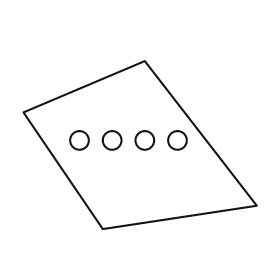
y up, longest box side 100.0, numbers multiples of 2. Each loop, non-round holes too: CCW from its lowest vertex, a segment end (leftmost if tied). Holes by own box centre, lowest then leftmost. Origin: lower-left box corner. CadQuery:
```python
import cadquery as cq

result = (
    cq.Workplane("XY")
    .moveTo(34.0, 0.0)
    .lineTo(100.0, 10.0)
    .lineTo(52.0, 72.0)
    .lineTo(0.0, 50.0)
    .close()
    .moveTo(24.0, 38.0)
    .circle(4.0)
    .moveTo(38.0, 38.0)
    .circle(4.0)
    .moveTo(52.0, 38.0)
    .circle(4.0)
    .moveTo(66.0, 38.0)
    .circle(4.0)
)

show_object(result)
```